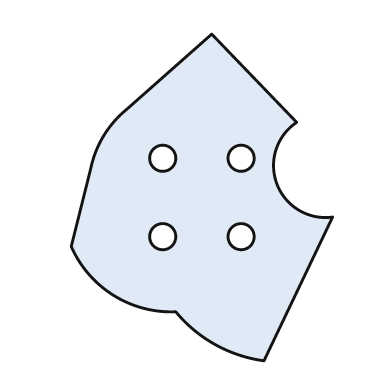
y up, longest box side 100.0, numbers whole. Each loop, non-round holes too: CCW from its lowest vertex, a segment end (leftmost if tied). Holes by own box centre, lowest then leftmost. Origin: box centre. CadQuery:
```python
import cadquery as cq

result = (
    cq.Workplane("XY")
    .moveTo(19.0, -50.0)
    .lineTo(40.0, -6.0)
    .threePointArc((23.0, 4.0), (29.0, 23.0))
    .lineTo(3.0, 50.0)
    .lineTo(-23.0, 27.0)
    .threePointArc((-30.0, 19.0), (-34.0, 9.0))
    .lineTo(-40.0, -15.0)
    .threePointArc((-27.0, -30.0), (-8.0, -35.0))
    .threePointArc((4.0, -45.0), (19.0, -50.0))
    .close()
    .moveTo(-12.0, -12.0)
    .circle(4.0)
    .moveTo(12.0, -12.0)
    .circle(4.0)
    .moveTo(-12.0, 12.0)
    .circle(4.0)
    .moveTo(12.0, 12.0)
    .circle(4.0)
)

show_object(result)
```